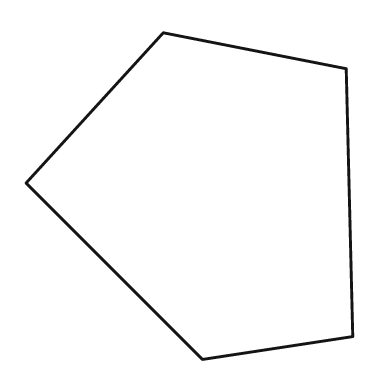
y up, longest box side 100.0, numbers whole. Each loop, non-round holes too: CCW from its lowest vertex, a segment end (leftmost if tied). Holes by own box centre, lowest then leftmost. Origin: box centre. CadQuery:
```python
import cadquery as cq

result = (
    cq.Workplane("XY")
    .moveTo(4.0, -50.0)
    .lineTo(50.0, -43.0)
    .lineTo(48.0, 39.0)
    .lineTo(-8.0, 50.0)
    .lineTo(-50.0, 4.0)
    .close()
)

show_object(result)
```